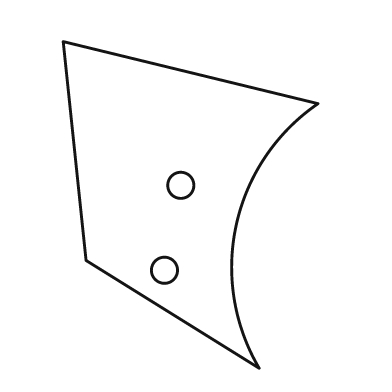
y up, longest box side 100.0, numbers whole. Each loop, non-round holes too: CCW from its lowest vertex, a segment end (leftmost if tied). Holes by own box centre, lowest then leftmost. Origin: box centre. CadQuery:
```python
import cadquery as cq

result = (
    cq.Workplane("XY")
    .moveTo(21.0, -50.0)
    .threePointArc((14.0, -6.0), (39.0, 31.0))
    .lineTo(-39.0, 50.0)
    .lineTo(-32.0, -17.0)
    .close()
    .moveTo(-8.0, -20.0)
    .circle(4.0)
    .moveTo(-3.0, 6.0)
    .circle(4.0)
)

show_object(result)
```